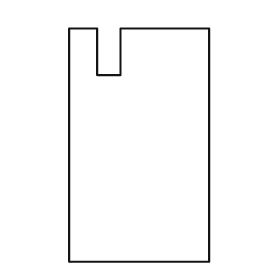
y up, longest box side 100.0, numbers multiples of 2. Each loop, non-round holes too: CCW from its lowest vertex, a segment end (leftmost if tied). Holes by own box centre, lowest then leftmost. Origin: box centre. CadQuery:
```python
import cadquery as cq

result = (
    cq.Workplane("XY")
    .moveTo(-30.0, -50.0)
    .lineTo(30.0, -50.0)
    .lineTo(30.0, 50.0)
    .lineTo(-8.0, 50.0)
    .lineTo(-8.0, 30.0)
    .lineTo(-18.0, 30.0)
    .lineTo(-18.0, 50.0)
    .lineTo(-30.0, 50.0)
    .close()
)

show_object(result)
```